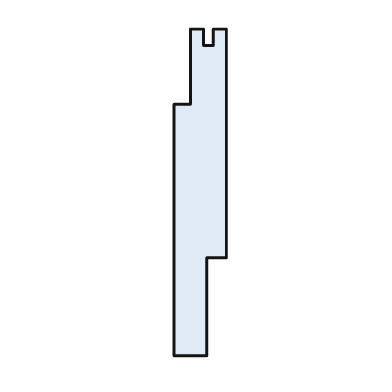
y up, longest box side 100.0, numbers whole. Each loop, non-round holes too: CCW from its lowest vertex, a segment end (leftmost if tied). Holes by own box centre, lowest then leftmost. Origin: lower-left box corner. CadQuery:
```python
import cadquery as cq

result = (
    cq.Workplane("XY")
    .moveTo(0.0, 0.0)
    .lineTo(10.0, 0.0)
    .lineTo(10.0, 30.0)
    .lineTo(16.0, 30.0)
    .lineTo(16.0, 100.0)
    .lineTo(12.0, 100.0)
    .lineTo(12.0, 95.0)
    .lineTo(9.0, 95.0)
    .lineTo(9.0, 100.0)
    .lineTo(5.0, 100.0)
    .lineTo(5.0, 77.0)
    .lineTo(0.0, 77.0)
    .close()
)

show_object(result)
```